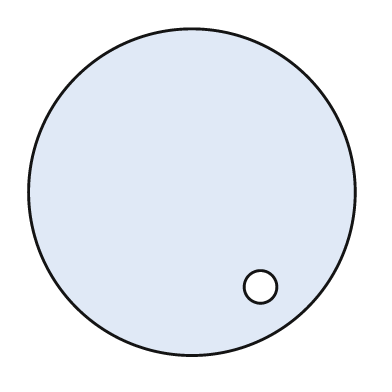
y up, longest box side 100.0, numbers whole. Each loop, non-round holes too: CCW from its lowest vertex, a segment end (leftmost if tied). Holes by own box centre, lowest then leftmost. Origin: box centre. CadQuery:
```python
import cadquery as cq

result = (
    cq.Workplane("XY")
    .moveTo(0.0, 0.0)
    .circle(50.0)
    .moveTo(21.0, -29.0)
    .circle(5.0)
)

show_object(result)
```